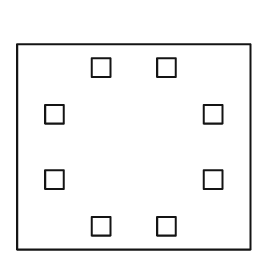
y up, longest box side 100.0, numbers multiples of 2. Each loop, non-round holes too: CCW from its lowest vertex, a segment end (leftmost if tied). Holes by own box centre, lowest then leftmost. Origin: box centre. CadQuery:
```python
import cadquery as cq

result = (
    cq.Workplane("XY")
    .moveTo(-50.0, -44.0)
    .lineTo(50.0, -44.0)
    .lineTo(50.0, 44.0)
    .lineTo(-50.0, 44.0)
    .close()
    .moveTo(-18.0, -38.0)
    .lineTo(-10.0, -38.0)
    .lineTo(-10.0, -30.0)
    .lineTo(-18.0, -30.0)
    .close()
    .moveTo(10.0, -38.0)
    .lineTo(18.0, -38.0)
    .lineTo(18.0, -30.0)
    .lineTo(10.0, -30.0)
    .close()
    .moveTo(-38.0, -18.0)
    .lineTo(-30.0, -18.0)
    .lineTo(-30.0, -10.0)
    .lineTo(-38.0, -10.0)
    .close()
    .moveTo(30.0, -18.0)
    .lineTo(38.0, -18.0)
    .lineTo(38.0, -10.0)
    .lineTo(30.0, -10.0)
    .close()
    .moveTo(-38.0, 10.0)
    .lineTo(-30.0, 10.0)
    .lineTo(-30.0, 18.0)
    .lineTo(-38.0, 18.0)
    .close()
    .moveTo(30.0, 10.0)
    .lineTo(38.0, 10.0)
    .lineTo(38.0, 18.0)
    .lineTo(30.0, 18.0)
    .close()
    .moveTo(-18.0, 30.0)
    .lineTo(-10.0, 30.0)
    .lineTo(-10.0, 38.0)
    .lineTo(-18.0, 38.0)
    .close()
    .moveTo(10.0, 30.0)
    .lineTo(18.0, 30.0)
    .lineTo(18.0, 38.0)
    .lineTo(10.0, 38.0)
    .close()
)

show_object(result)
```